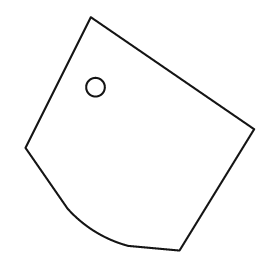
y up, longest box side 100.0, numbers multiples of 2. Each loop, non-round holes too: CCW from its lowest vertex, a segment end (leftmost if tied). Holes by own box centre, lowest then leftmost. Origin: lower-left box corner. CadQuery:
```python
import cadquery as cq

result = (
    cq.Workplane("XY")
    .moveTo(66.0, 0.0)
    .lineTo(98.0, 52.0)
    .lineTo(28.0, 100.0)
    .lineTo(0.0, 44.0)
    .lineTo(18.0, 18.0)
    .threePointArc((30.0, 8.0), (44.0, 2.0))
    .close()
    .moveTo(30.0, 70.0)
    .circle(4.0)
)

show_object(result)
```